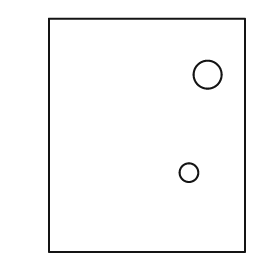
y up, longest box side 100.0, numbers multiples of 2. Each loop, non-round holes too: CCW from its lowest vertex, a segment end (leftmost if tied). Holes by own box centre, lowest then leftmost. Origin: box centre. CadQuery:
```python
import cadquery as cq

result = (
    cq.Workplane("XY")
    .moveTo(-42.0, -50.0)
    .lineTo(42.0, -50.0)
    .lineTo(42.0, 50.0)
    .lineTo(-42.0, 50.0)
    .close()
    .moveTo(18.0, -16.0)
    .circle(4.0)
    .moveTo(26.0, 26.0)
    .circle(6.0)
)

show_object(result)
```